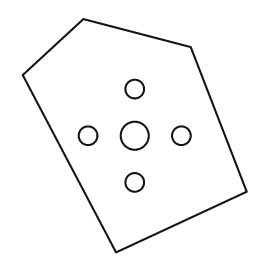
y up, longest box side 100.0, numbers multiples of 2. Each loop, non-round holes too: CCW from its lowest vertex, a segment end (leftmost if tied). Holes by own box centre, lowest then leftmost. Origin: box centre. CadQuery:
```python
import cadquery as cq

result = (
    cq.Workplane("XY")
    .moveTo(-8.0, -50.0)
    .lineTo(48.0, -24.0)
    .lineTo(24.0, 38.0)
    .lineTo(-22.0, 50.0)
    .lineTo(-48.0, 26.0)
    .close()
    .moveTo(0.0, -20.0)
    .circle(4.0)
    .moveTo(-20.0, 0.0)
    .circle(4.0)
    .moveTo(0.0, 0.0)
    .circle(6.0)
    .moveTo(20.0, 0.0)
    .circle(4.0)
    .moveTo(0.0, 20.0)
    .circle(4.0)
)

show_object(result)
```